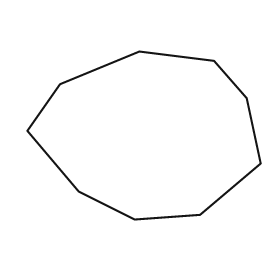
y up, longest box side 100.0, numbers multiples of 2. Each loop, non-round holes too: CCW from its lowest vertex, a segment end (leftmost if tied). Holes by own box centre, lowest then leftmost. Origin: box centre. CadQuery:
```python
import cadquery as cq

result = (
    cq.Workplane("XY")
    .moveTo(-4.0, -36.0)
    .lineTo(24.0, -34.0)
    .lineTo(50.0, -12.0)
    .lineTo(44.0, 16.0)
    .lineTo(30.0, 32.0)
    .lineTo(-2.0, 36.0)
    .lineTo(-36.0, 22.0)
    .lineTo(-50.0, 2.0)
    .lineTo(-28.0, -24.0)
    .close()
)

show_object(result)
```